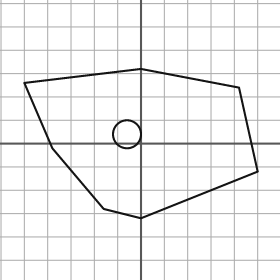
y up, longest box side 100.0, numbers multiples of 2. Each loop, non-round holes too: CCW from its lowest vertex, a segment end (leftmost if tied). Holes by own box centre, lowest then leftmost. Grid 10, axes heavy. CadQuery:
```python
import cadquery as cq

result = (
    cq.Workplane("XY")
    .moveTo(0.0, -32.0)
    .lineTo(50.0, -12.0)
    .lineTo(42.0, 24.0)
    .lineTo(0.0, 32.0)
    .lineTo(-50.0, 26.0)
    .lineTo(-38.0, -2.0)
    .lineTo(-16.0, -28.0)
    .close()
    .moveTo(-6.0, 4.0)
    .circle(6.0)
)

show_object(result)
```